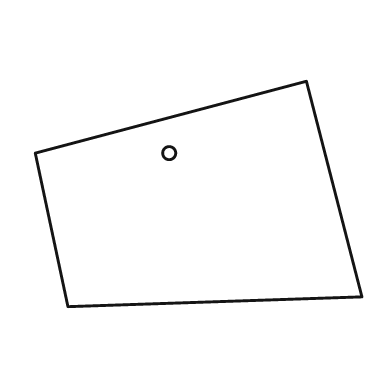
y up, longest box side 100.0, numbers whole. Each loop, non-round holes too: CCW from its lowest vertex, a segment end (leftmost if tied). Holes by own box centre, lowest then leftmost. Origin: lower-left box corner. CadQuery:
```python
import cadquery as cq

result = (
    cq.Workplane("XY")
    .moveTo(10.0, 0.0)
    .lineTo(100.0, 3.0)
    .lineTo(83.0, 69.0)
    .lineTo(0.0, 47.0)
    .close()
    .moveTo(41.0, 47.0)
    .circle(2.0)
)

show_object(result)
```